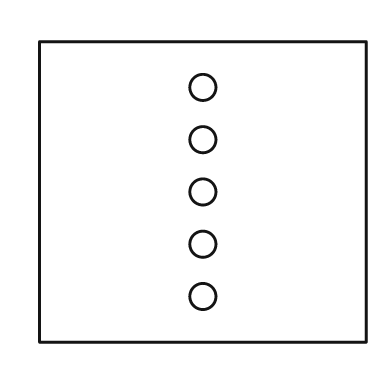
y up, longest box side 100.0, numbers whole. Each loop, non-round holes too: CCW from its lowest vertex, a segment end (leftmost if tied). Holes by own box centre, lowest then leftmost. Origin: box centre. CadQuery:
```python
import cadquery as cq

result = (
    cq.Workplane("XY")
    .moveTo(-50.0, -46.0)
    .lineTo(50.0, -46.0)
    .lineTo(50.0, 46.0)
    .lineTo(-50.0, 46.0)
    .close()
    .moveTo(0.0, -32.0)
    .circle(4.0)
    .moveTo(0.0, -16.0)
    .circle(4.0)
    .moveTo(0.0, 0.0)
    .circle(4.0)
    .moveTo(0.0, 16.0)
    .circle(4.0)
    .moveTo(0.0, 32.0)
    .circle(4.0)
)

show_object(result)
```